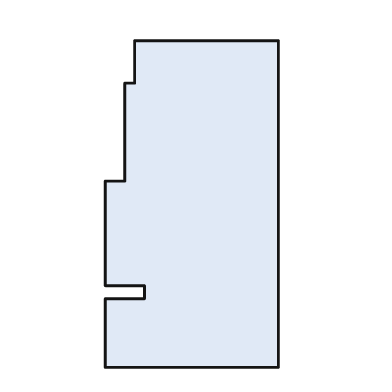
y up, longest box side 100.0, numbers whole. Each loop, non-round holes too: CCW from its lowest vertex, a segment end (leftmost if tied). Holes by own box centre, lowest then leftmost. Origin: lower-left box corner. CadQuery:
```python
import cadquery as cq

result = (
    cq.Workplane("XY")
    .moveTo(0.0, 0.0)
    .lineTo(53.0, 0.0)
    .lineTo(53.0, 100.0)
    .lineTo(9.0, 100.0)
    .lineTo(9.0, 87.0)
    .lineTo(6.0, 87.0)
    .lineTo(6.0, 57.0)
    .lineTo(0.0, 57.0)
    .lineTo(0.0, 25.0)
    .lineTo(12.0, 25.0)
    .lineTo(12.0, 21.0)
    .lineTo(0.0, 21.0)
    .close()
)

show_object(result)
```